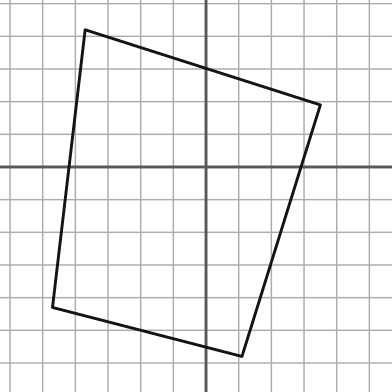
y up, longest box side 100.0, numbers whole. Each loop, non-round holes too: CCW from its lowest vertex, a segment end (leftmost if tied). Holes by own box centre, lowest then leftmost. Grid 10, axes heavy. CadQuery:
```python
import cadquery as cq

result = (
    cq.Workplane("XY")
    .moveTo(11.0, -58.0)
    .lineTo(35.0, 19.0)
    .lineTo(-37.0, 42.0)
    .lineTo(-47.0, -43.0)
    .close()
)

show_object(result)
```